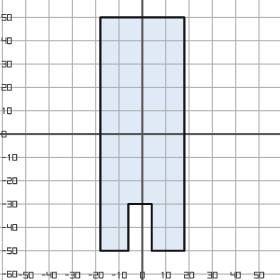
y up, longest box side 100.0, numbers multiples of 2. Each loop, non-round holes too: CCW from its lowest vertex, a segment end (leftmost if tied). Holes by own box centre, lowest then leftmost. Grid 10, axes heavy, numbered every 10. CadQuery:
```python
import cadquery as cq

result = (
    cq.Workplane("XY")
    .moveTo(-18.0, -50.0)
    .lineTo(-6.0, -50.0)
    .lineTo(-6.0, -30.0)
    .lineTo(4.0, -30.0)
    .lineTo(4.0, -50.0)
    .lineTo(18.0, -50.0)
    .lineTo(18.0, 50.0)
    .lineTo(-18.0, 50.0)
    .close()
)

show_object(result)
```